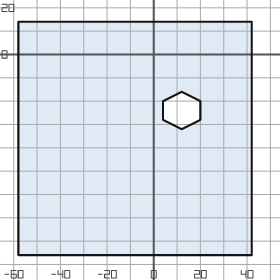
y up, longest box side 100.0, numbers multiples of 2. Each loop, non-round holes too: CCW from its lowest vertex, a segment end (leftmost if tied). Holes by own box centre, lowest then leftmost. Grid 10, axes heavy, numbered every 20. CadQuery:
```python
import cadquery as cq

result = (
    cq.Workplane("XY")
    .moveTo(-58.0, -86.0)
    .lineTo(42.0, -86.0)
    .lineTo(42.0, 14.0)
    .lineTo(-58.0, 14.0)
    .close()
    .moveTo(12.0, -32.0)
    .lineTo(20.0, -28.0)
    .lineTo(20.0, -20.0)
    .lineTo(12.0, -16.0)
    .lineTo(4.0, -20.0)
    .lineTo(4.0, -28.0)
    .close()
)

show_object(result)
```